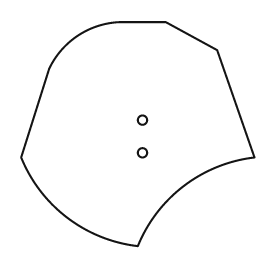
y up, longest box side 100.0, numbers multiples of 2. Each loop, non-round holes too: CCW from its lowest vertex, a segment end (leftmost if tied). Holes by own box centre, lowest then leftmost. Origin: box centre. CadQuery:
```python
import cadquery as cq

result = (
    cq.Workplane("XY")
    .moveTo(0.0, -48.0)
    .threePointArc((20.0, -22.0), (50.0, -10.0))
    .lineTo(34.0, 36.0)
    .lineTo(12.0, 48.0)
    .lineTo(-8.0, 48.0)
    .threePointArc((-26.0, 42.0), (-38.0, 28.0))
    .lineTo(-50.0, -10.0)
    .threePointArc((-30.0, -36.0), (0.0, -48.0))
    .close()
    .moveTo(2.0, -8.0)
    .circle(2.0)
    .moveTo(2.0, 6.0)
    .circle(2.0)
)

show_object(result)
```